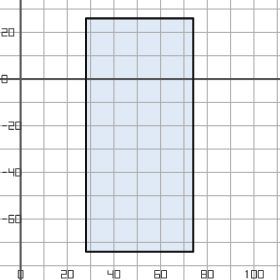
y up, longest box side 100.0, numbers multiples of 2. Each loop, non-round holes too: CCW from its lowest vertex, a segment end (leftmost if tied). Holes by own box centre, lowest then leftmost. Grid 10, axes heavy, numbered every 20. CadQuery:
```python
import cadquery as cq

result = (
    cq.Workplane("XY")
    .moveTo(28.0, -74.0)
    .lineTo(74.0, -74.0)
    .lineTo(74.0, 26.0)
    .lineTo(28.0, 26.0)
    .close()
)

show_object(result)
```